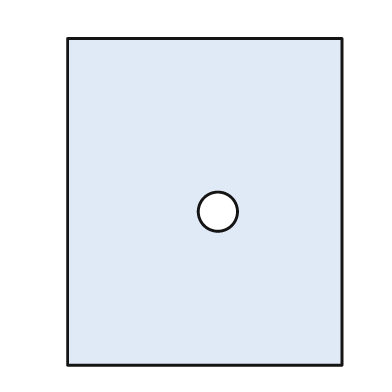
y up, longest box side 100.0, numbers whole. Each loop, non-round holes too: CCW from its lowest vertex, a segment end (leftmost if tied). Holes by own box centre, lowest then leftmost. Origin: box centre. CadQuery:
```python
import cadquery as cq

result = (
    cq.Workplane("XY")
    .moveTo(-42.0, -50.0)
    .lineTo(42.0, -50.0)
    .lineTo(42.0, 50.0)
    .lineTo(-42.0, 50.0)
    .close()
    .moveTo(4.0, -3.0)
    .circle(6.0)
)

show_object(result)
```